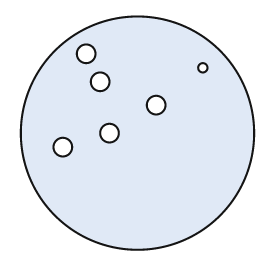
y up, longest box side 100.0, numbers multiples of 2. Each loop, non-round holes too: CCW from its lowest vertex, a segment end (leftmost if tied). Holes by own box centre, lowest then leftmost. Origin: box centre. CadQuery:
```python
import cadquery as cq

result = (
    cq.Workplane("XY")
    .moveTo(0.0, 0.0)
    .circle(50.0)
    .moveTo(-32.0, -6.0)
    .circle(4.0)
    .moveTo(-12.0, 0.0)
    .circle(4.0)
    .moveTo(8.0, 12.0)
    .circle(4.0)
    .moveTo(-16.0, 22.0)
    .circle(4.0)
    .moveTo(28.0, 28.0)
    .circle(2.0)
    .moveTo(-22.0, 34.0)
    .circle(4.0)
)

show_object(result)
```